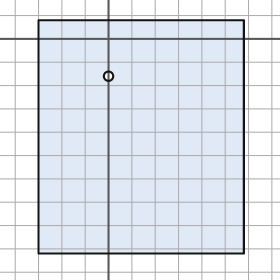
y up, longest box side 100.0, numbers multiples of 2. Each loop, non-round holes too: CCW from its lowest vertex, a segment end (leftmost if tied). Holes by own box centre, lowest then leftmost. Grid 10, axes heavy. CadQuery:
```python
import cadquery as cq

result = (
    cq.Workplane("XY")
    .moveTo(-30.0, -92.0)
    .lineTo(58.0, -92.0)
    .lineTo(58.0, 8.0)
    .lineTo(-30.0, 8.0)
    .close()
    .moveTo(0.0, -16.0)
    .circle(2.0)
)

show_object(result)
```